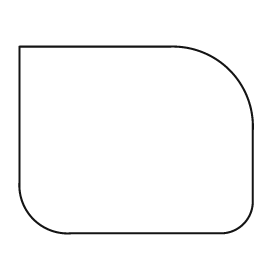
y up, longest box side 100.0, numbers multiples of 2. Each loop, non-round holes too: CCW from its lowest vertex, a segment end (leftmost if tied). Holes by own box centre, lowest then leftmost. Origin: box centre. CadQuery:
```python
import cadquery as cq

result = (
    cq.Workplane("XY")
    .moveTo(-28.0, -40.0)
    .lineTo(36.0, -40.0)
    .threePointArc((46.0, -36.0), (50.0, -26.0))
    .lineTo(50.0, 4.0)
    .threePointArc((40.0, 30.0), (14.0, 40.0))
    .lineTo(-50.0, 40.0)
    .lineTo(-50.0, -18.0)
    .threePointArc((-44.0, -34.0), (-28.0, -40.0))
    .close()
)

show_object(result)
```